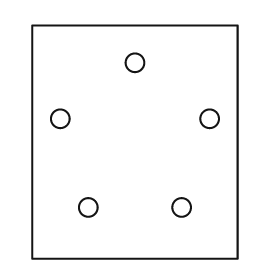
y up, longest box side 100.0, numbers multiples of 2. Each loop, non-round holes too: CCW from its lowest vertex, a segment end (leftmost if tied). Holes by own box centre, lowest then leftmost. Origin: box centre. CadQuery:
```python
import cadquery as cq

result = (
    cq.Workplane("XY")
    .moveTo(-44.0, -50.0)
    .lineTo(44.0, -50.0)
    .lineTo(44.0, 50.0)
    .lineTo(-44.0, 50.0)
    .close()
    .moveTo(-20.0, -28.0)
    .circle(4.0)
    .moveTo(20.0, -28.0)
    .circle(4.0)
    .moveTo(-32.0, 10.0)
    .circle(4.0)
    .moveTo(32.0, 10.0)
    .circle(4.0)
    .moveTo(0.0, 34.0)
    .circle(4.0)
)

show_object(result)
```